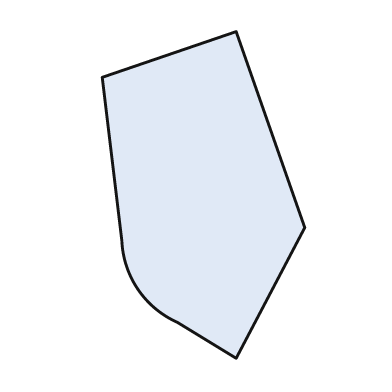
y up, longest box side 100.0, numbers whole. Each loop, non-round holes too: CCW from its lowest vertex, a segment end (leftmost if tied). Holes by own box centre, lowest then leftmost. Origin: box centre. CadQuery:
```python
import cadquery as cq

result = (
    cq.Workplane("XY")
    .moveTo(10.0, -50.0)
    .lineTo(31.0, -10.0)
    .lineTo(10.0, 50.0)
    .lineTo(-31.0, 36.0)
    .lineTo(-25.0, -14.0)
    .threePointArc((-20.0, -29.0), (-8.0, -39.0))
    .close()
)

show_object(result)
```